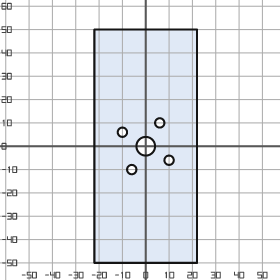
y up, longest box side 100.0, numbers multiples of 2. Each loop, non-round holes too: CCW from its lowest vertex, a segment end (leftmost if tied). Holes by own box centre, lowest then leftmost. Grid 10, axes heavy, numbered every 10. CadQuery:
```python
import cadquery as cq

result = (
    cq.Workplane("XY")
    .moveTo(-22.0, -50.0)
    .lineTo(22.0, -50.0)
    .lineTo(22.0, 50.0)
    .lineTo(-22.0, 50.0)
    .close()
    .moveTo(-6.0, -10.0)
    .circle(2.0)
    .moveTo(10.0, -6.0)
    .circle(2.0)
    .moveTo(0.0, 0.0)
    .circle(4.0)
    .moveTo(-10.0, 6.0)
    .circle(2.0)
    .moveTo(6.0, 10.0)
    .circle(2.0)
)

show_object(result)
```